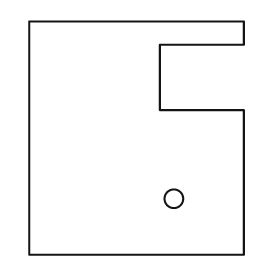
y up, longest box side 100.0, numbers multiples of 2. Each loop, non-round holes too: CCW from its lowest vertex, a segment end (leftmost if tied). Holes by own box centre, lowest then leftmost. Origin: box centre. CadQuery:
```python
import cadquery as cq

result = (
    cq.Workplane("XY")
    .moveTo(-46.0, -50.0)
    .lineTo(46.0, -50.0)
    .lineTo(46.0, 12.0)
    .lineTo(10.0, 12.0)
    .lineTo(10.0, 40.0)
    .lineTo(46.0, 40.0)
    .lineTo(46.0, 50.0)
    .lineTo(-46.0, 50.0)
    .close()
    .moveTo(16.0, -26.0)
    .circle(4.0)
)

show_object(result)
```